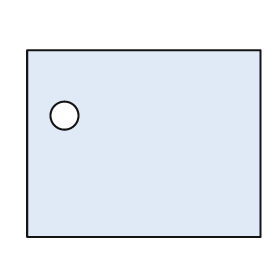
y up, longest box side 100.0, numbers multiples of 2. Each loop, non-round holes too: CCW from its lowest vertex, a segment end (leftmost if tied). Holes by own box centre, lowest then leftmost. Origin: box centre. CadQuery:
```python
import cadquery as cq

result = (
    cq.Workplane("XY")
    .moveTo(-50.0, -40.0)
    .lineTo(50.0, -40.0)
    .lineTo(50.0, 40.0)
    .lineTo(-50.0, 40.0)
    .close()
    .moveTo(-34.0, 12.0)
    .circle(6.0)
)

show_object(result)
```